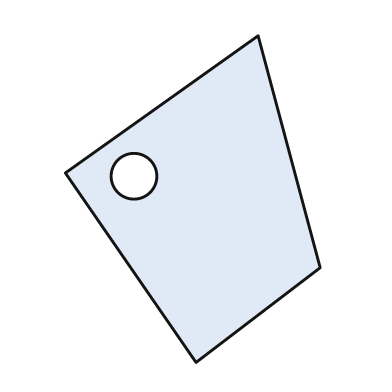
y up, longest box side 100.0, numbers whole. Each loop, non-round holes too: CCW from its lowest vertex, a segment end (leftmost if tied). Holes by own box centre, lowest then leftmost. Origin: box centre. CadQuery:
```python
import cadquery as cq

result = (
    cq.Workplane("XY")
    .moveTo(1.0, -50.0)
    .lineTo(39.0, -21.0)
    .lineTo(20.0, 50.0)
    .lineTo(-39.0, 8.0)
    .close()
    .moveTo(-18.0, 7.0)
    .circle(7.0)
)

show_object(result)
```